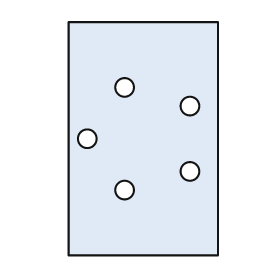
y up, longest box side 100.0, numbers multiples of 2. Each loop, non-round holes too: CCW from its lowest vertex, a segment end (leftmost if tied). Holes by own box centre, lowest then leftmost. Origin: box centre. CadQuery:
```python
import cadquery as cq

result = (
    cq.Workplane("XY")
    .moveTo(-32.0, -50.0)
    .lineTo(32.0, -50.0)
    .lineTo(32.0, 50.0)
    .lineTo(-32.0, 50.0)
    .close()
    .moveTo(-8.0, -22.0)
    .circle(4.0)
    .moveTo(20.0, -14.0)
    .circle(4.0)
    .moveTo(-24.0, 0.0)
    .circle(4.0)
    .moveTo(20.0, 14.0)
    .circle(4.0)
    .moveTo(-8.0, 22.0)
    .circle(4.0)
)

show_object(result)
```